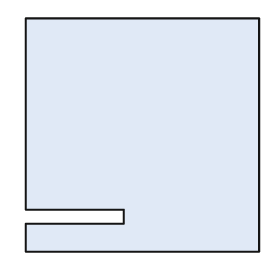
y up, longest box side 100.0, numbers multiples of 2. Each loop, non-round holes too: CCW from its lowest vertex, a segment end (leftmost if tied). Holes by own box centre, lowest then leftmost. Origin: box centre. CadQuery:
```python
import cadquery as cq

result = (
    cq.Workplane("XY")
    .moveTo(-50.0, -50.0)
    .lineTo(50.0, -50.0)
    .lineTo(50.0, 50.0)
    .lineTo(-50.0, 50.0)
    .lineTo(-50.0, -32.0)
    .lineTo(-8.0, -32.0)
    .lineTo(-8.0, -38.0)
    .lineTo(-50.0, -38.0)
    .close()
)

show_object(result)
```